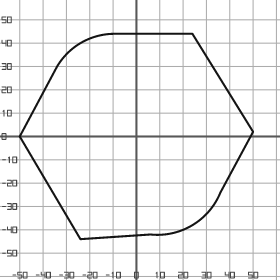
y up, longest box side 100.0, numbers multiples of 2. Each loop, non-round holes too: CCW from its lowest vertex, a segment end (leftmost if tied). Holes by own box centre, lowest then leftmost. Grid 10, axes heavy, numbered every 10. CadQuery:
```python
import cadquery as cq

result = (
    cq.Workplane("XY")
    .moveTo(-24.0, -44.0)
    .lineTo(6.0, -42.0)
    .threePointArc((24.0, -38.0), (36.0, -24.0))
    .lineTo(50.0, 2.0)
    .lineTo(24.0, 44.0)
    .lineTo(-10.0, 44.0)
    .threePointArc((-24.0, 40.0), (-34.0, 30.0))
    .lineTo(-50.0, 0.0)
    .close()
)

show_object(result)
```